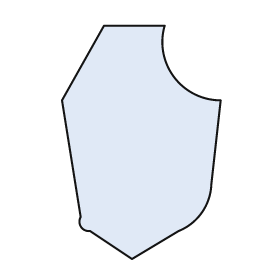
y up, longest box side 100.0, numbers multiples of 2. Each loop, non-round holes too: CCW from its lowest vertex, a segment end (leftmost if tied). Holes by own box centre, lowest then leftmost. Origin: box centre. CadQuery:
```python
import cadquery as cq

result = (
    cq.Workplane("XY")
    .moveTo(-4.0, -50.0)
    .lineTo(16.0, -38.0)
    .threePointArc((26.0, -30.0), (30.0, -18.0))
    .lineTo(34.0, 18.0)
    .threePointArc((14.0, 28.0), (10.0, 50.0))
    .lineTo(-16.0, 50.0)
    .lineTo(-34.0, 18.0)
    .lineTo(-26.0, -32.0)
    .threePointArc((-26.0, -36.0), (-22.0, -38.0))
    .close()
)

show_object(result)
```